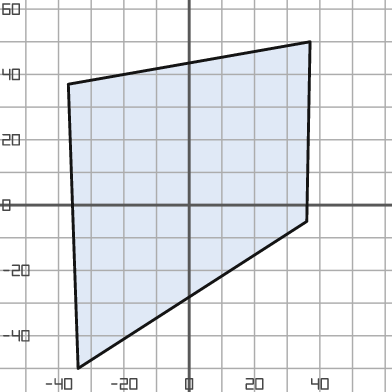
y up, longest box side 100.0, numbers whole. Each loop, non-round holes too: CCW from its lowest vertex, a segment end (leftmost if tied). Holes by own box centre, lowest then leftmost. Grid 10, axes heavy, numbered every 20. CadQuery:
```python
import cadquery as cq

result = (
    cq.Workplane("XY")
    .moveTo(-34.0, -50.0)
    .lineTo(36.0, -5.0)
    .lineTo(37.0, 50.0)
    .lineTo(-37.0, 37.0)
    .close()
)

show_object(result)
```